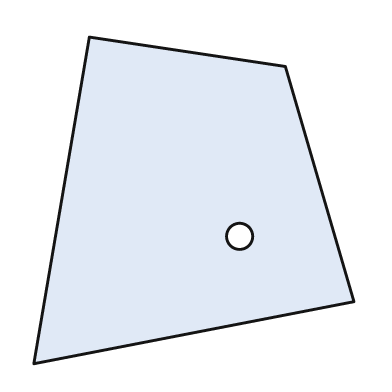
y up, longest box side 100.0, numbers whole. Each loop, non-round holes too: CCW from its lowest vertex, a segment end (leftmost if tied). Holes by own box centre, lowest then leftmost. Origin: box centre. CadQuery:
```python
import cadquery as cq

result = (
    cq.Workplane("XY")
    .moveTo(-49.0, -50.0)
    .lineTo(49.0, -31.0)
    .lineTo(28.0, 41.0)
    .lineTo(-32.0, 50.0)
    .close()
    .moveTo(14.0, -11.0)
    .circle(4.0)
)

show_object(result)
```